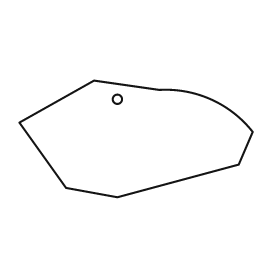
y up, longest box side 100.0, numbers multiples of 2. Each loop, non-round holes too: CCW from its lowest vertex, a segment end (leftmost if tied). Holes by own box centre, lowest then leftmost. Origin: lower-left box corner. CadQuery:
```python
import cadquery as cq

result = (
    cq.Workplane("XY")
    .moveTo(42.0, 0.0)
    .lineTo(94.0, 14.0)
    .lineTo(100.0, 28.0)
    .threePointArc((82.0, 42.0), (60.0, 46.0))
    .lineTo(32.0, 50.0)
    .lineTo(0.0, 32.0)
    .lineTo(20.0, 4.0)
    .close()
    .moveTo(42.0, 42.0)
    .circle(2.0)
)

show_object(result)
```